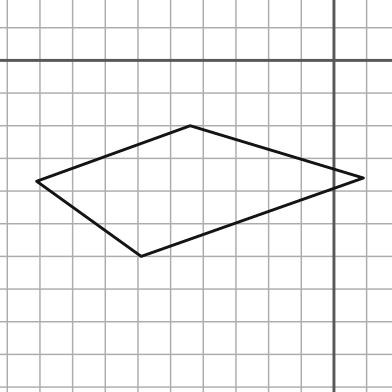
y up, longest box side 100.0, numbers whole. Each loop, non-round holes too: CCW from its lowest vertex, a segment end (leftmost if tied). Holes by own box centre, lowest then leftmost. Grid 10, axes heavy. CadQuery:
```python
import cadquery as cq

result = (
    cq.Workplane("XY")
    .moveTo(-59.0, -60.0)
    .lineTo(9.0, -36.0)
    .lineTo(-44.0, -20.0)
    .lineTo(-91.0, -37.0)
    .close()
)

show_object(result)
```